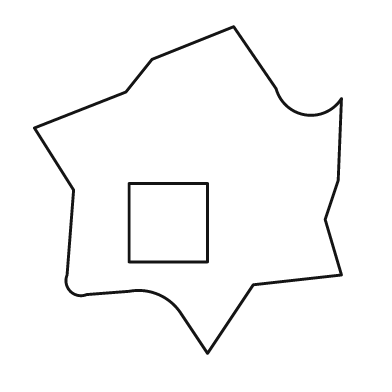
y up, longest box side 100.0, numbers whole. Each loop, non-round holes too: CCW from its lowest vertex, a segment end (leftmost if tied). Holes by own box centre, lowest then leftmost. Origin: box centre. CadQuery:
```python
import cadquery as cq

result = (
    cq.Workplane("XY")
    .moveTo(6.0, -50.0)
    .lineTo(20.0, -29.0)
    .lineTo(47.0, -26.0)
    .lineTo(42.0, -9.0)
    .lineTo(46.0, 3.0)
    .lineTo(47.0, 28.0)
    .threePointArc((36.0, 23.0), (27.0, 31.0))
    .lineTo(14.0, 50.0)
    .lineTo(-11.0, 40.0)
    .lineTo(-19.0, 30.0)
    .lineTo(-47.0, 19.0)
    .lineTo(-35.0, 0.0)
    .lineTo(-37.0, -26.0)
    .threePointArc((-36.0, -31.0), (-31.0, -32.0))
    .lineTo(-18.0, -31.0)
    .threePointArc((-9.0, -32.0), (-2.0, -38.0))
    .close()
    .moveTo(-18.0, -22.0)
    .lineTo(6.0, -22.0)
    .lineTo(6.0, 2.0)
    .lineTo(-18.0, 2.0)
    .close()
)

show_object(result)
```